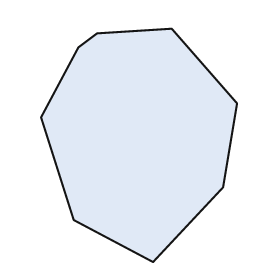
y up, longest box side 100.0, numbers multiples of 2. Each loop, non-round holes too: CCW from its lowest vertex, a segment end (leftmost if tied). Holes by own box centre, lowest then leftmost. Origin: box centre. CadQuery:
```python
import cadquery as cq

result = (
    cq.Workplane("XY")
    .moveTo(6.0, -50.0)
    .lineTo(36.0, -18.0)
    .lineTo(42.0, 18.0)
    .lineTo(14.0, 50.0)
    .lineTo(-18.0, 48.0)
    .lineTo(-26.0, 42.0)
    .lineTo(-42.0, 12.0)
    .lineTo(-28.0, -32.0)
    .close()
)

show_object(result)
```